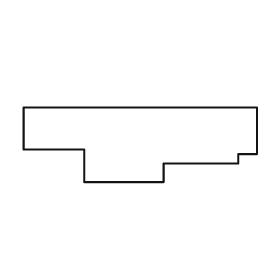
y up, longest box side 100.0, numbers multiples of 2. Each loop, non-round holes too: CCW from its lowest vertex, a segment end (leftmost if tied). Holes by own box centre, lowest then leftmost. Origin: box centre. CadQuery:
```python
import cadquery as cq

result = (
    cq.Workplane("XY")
    .moveTo(-24.0, -16.0)
    .lineTo(10.0, -16.0)
    .lineTo(10.0, -8.0)
    .lineTo(42.0, -8.0)
    .lineTo(42.0, -4.0)
    .lineTo(50.0, -4.0)
    .lineTo(50.0, 16.0)
    .lineTo(-50.0, 16.0)
    .lineTo(-50.0, -2.0)
    .lineTo(-24.0, -2.0)
    .close()
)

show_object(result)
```